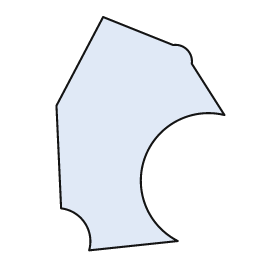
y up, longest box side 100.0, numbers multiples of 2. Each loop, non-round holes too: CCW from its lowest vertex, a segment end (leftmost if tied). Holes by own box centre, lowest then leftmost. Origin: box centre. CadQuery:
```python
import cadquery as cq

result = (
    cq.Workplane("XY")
    .moveTo(-22.0, -50.0)
    .lineTo(16.0, -46.0)
    .threePointArc((2.0, -10.0), (36.0, 8.0))
    .lineTo(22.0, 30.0)
    .threePointArc((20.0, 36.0), (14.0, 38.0))
    .lineTo(-16.0, 50.0)
    .lineTo(-36.0, 12.0)
    .lineTo(-34.0, -32.0)
    .threePointArc((-24.0, -38.0), (-22.0, -50.0))
    .close()
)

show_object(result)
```